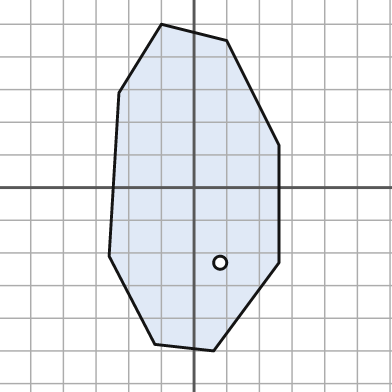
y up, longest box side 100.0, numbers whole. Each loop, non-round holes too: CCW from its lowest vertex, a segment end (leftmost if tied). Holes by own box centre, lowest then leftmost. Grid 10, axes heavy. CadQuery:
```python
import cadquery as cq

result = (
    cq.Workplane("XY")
    .moveTo(6.0, -50.0)
    .lineTo(26.0, -23.0)
    .lineTo(26.0, 13.0)
    .lineTo(10.0, 45.0)
    .lineTo(-10.0, 50.0)
    .lineTo(-23.0, 29.0)
    .lineTo(-26.0, -21.0)
    .lineTo(-12.0, -48.0)
    .close()
    .moveTo(8.0, -23.0)
    .circle(2.0)
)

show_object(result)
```